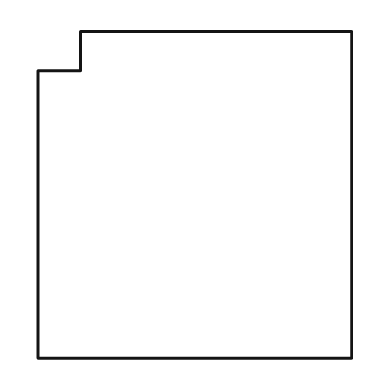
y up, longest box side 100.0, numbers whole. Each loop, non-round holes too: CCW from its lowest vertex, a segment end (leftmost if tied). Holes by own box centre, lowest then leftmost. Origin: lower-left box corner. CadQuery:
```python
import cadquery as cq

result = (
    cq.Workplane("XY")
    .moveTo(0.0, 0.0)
    .lineTo(96.0, 0.0)
    .lineTo(96.0, 100.0)
    .lineTo(13.0, 100.0)
    .lineTo(13.0, 88.0)
    .lineTo(0.0, 88.0)
    .close()
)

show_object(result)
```